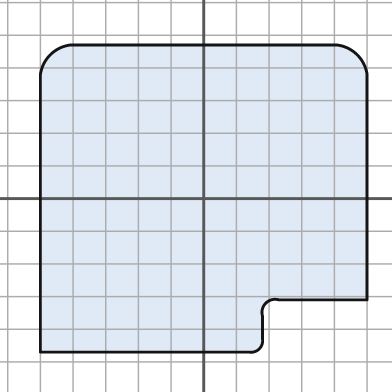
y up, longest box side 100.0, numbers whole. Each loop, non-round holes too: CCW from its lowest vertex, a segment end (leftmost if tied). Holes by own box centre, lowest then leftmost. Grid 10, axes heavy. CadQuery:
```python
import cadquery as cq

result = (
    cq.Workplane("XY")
    .moveTo(-50.0, -47.0)
    .lineTo(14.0, -47.0)
    .threePointArc((17.0, -46.0), (18.0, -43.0))
    .lineTo(18.0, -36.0)
    .threePointArc((19.0, -32.0), (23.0, -31.0))
    .lineTo(50.0, -31.0)
    .lineTo(50.0, 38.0)
    .threePointArc((47.0, 44.0), (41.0, 47.0))
    .lineTo(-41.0, 47.0)
    .threePointArc((-47.0, 44.0), (-50.0, 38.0))
    .close()
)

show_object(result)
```